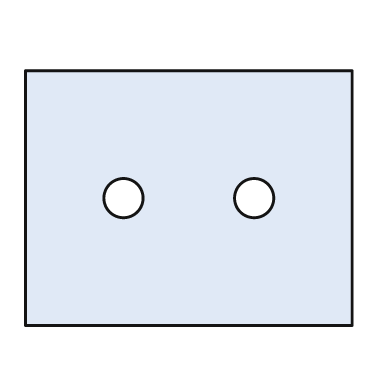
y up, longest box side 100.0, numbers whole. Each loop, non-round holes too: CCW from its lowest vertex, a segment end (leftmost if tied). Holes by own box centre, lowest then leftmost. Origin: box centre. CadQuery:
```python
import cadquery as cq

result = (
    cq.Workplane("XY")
    .moveTo(-50.0, -39.0)
    .lineTo(50.0, -39.0)
    .lineTo(50.0, 39.0)
    .lineTo(-50.0, 39.0)
    .close()
    .moveTo(-20.0, 0.0)
    .circle(6.0)
    .moveTo(20.0, 0.0)
    .circle(6.0)
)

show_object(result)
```